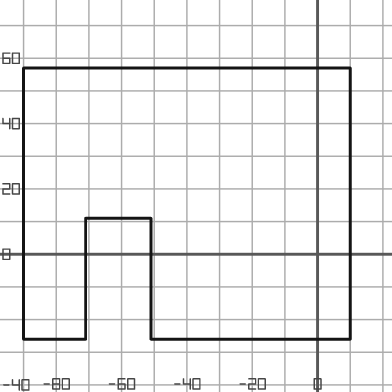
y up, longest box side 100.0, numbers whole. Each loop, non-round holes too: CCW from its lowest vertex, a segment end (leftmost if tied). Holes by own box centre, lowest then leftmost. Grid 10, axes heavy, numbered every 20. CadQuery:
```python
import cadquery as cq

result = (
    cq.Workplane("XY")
    .moveTo(-90.0, -26.0)
    .lineTo(-71.0, -26.0)
    .lineTo(-71.0, 11.0)
    .lineTo(-51.0, 11.0)
    .lineTo(-51.0, -26.0)
    .lineTo(10.0, -26.0)
    .lineTo(10.0, 57.0)
    .lineTo(-90.0, 57.0)
    .close()
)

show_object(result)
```